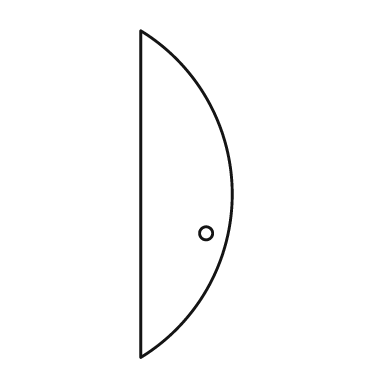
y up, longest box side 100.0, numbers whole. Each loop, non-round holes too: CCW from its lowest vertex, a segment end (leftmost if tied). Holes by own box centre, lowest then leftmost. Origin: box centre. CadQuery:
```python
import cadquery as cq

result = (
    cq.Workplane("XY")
    .moveTo(-14.0, -50.0)
    .threePointArc((14.0, 0.0), (-14.0, 50.0))
    .close()
    .moveTo(6.0, -12.0)
    .circle(2.0)
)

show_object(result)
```